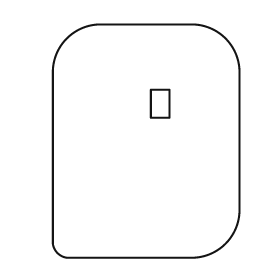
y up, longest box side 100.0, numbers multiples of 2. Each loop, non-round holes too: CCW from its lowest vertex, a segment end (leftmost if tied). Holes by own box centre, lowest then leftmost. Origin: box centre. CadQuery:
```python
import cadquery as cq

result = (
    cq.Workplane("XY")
    .moveTo(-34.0, -50.0)
    .lineTo(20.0, -50.0)
    .threePointArc((34.0, -44.0), (40.0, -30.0))
    .lineTo(40.0, 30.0)
    .threePointArc((34.0, 44.0), (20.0, 50.0))
    .lineTo(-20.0, 50.0)
    .threePointArc((-34.0, 44.0), (-40.0, 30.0))
    .lineTo(-40.0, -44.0)
    .threePointArc((-38.0, -48.0), (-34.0, -50.0))
    .close()
    .moveTo(2.0, 10.0)
    .lineTo(10.0, 10.0)
    .lineTo(10.0, 22.0)
    .lineTo(2.0, 22.0)
    .close()
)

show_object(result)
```